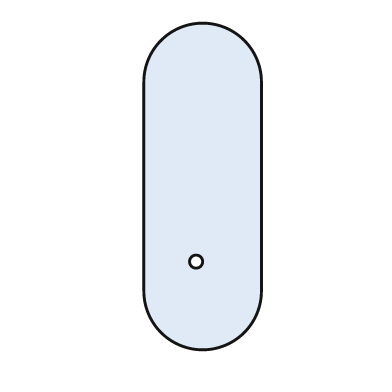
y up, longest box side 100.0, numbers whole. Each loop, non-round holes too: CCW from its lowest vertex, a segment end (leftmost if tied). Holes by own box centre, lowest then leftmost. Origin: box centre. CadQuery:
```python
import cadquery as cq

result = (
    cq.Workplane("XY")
    .moveTo(-18.0, -32.0)
    .threePointArc((0.0, -50.0), (18.0, -32.0))
    .lineTo(18.0, 32.0)
    .threePointArc((0.0, 50.0), (-18.0, 32.0))
    .close()
    .moveTo(-2.0, -23.0)
    .circle(2.0)
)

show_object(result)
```